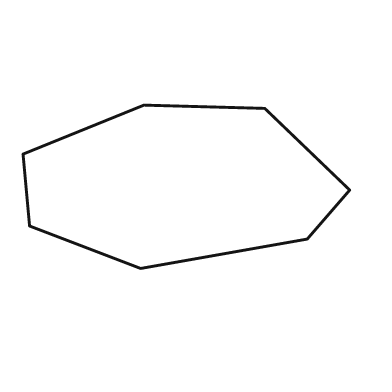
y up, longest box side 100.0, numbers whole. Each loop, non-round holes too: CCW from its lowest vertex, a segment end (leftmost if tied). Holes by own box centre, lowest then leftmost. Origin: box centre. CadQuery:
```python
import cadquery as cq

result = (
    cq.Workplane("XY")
    .moveTo(-14.0, -25.0)
    .lineTo(37.0, -16.0)
    .lineTo(50.0, -1.0)
    .lineTo(24.0, 24.0)
    .lineTo(-13.0, 25.0)
    .lineTo(-50.0, 10.0)
    .lineTo(-48.0, -12.0)
    .close()
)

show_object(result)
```